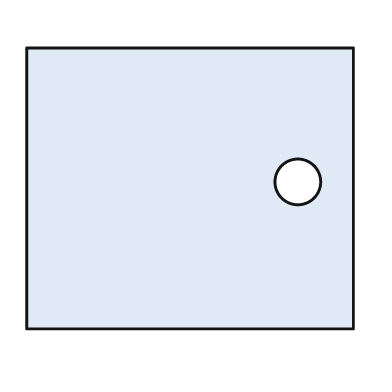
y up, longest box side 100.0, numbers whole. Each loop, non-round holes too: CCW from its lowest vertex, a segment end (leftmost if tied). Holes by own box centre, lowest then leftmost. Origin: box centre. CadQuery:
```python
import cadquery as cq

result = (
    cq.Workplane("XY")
    .moveTo(-50.0, -43.0)
    .lineTo(50.0, -43.0)
    .lineTo(50.0, 43.0)
    .lineTo(-50.0, 43.0)
    .close()
    .moveTo(33.0, 2.0)
    .circle(7.0)
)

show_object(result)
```